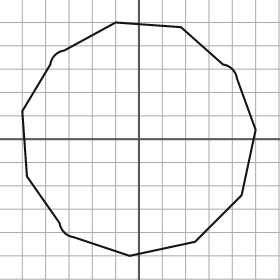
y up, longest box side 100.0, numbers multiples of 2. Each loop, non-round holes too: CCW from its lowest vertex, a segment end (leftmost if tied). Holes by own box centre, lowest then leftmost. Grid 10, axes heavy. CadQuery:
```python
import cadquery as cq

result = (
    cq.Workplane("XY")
    .moveTo(-4.0, -50.0)
    .lineTo(24.0, -44.0)
    .lineTo(44.0, -24.0)
    .lineTo(50.0, 4.0)
    .lineTo(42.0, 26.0)
    .threePointArc((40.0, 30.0), (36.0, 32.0))
    .lineTo(18.0, 48.0)
    .lineTo(-10.0, 50.0)
    .lineTo(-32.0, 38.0)
    .threePointArc((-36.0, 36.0), (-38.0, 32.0))
    .lineTo(-50.0, 12.0)
    .lineTo(-48.0, -16.0)
    .lineTo(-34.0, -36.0)
    .threePointArc((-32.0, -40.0), (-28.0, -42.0))
    .close()
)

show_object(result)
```